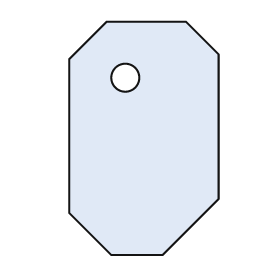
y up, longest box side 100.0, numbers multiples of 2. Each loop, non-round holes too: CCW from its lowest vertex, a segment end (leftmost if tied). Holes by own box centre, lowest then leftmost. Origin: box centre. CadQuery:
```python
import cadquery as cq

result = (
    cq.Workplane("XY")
    .moveTo(-14.0, -50.0)
    .lineTo(8.0, -50.0)
    .lineTo(32.0, -26.0)
    .lineTo(32.0, 36.0)
    .lineTo(18.0, 50.0)
    .lineTo(-16.0, 50.0)
    .lineTo(-32.0, 34.0)
    .lineTo(-32.0, -32.0)
    .close()
    .moveTo(-8.0, 26.0)
    .circle(6.0)
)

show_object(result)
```